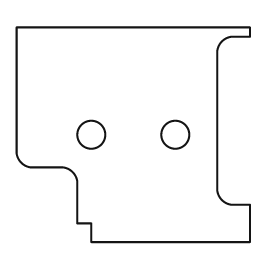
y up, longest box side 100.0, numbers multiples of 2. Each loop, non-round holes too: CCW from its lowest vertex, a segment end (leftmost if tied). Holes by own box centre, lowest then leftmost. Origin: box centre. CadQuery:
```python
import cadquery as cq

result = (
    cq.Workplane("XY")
    .moveTo(-18.0, -46.0)
    .lineTo(50.0, -46.0)
    .lineTo(50.0, -30.0)
    .lineTo(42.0, -30.0)
    .threePointArc((38.0, -28.0), (36.0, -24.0))
    .lineTo(36.0, 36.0)
    .threePointArc((38.0, 40.0), (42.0, 42.0))
    .lineTo(50.0, 42.0)
    .lineTo(50.0, 46.0)
    .lineTo(-50.0, 46.0)
    .lineTo(-50.0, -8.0)
    .threePointArc((-48.0, -12.0), (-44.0, -14.0))
    .lineTo(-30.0, -14.0)
    .threePointArc((-26.0, -16.0), (-24.0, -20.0))
    .lineTo(-24.0, -38.0)
    .lineTo(-18.0, -38.0)
    .close()
    .moveTo(-18.0, 0.0)
    .circle(6.0)
    .moveTo(18.0, 0.0)
    .circle(6.0)
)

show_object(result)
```